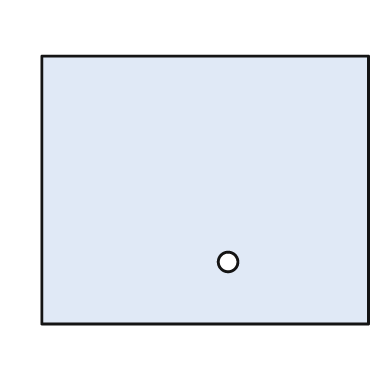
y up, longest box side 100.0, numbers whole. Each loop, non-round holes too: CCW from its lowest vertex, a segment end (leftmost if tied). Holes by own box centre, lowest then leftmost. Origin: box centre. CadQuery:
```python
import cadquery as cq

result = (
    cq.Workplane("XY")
    .moveTo(-50.0, -41.0)
    .lineTo(50.0, -41.0)
    .lineTo(50.0, 41.0)
    .lineTo(-50.0, 41.0)
    .close()
    .moveTo(7.0, -22.0)
    .circle(3.0)
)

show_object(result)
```